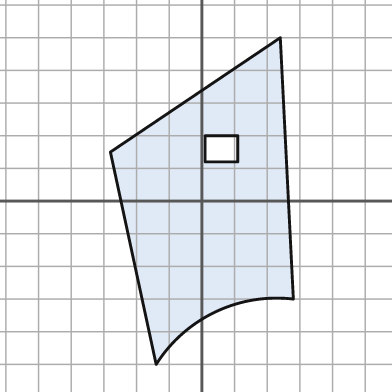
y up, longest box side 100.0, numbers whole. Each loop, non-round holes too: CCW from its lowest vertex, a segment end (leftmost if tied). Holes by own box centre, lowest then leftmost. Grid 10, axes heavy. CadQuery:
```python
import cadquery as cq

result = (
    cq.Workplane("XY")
    .moveTo(-14.0, -50.0)
    .threePointArc((4.0, -34.0), (28.0, -30.0))
    .lineTo(24.0, 50.0)
    .lineTo(-28.0, 15.0)
    .close()
    .moveTo(1.0, 12.0)
    .lineTo(11.0, 12.0)
    .lineTo(11.0, 20.0)
    .lineTo(1.0, 20.0)
    .close()
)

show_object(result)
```